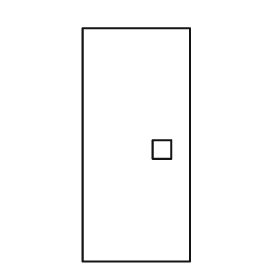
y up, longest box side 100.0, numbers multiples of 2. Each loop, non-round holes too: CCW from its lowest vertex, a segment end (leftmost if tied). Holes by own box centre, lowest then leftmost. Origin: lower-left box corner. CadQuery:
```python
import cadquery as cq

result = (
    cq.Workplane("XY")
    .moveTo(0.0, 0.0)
    .lineTo(46.0, 0.0)
    .lineTo(46.0, 100.0)
    .lineTo(0.0, 100.0)
    .close()
    .moveTo(30.0, 44.0)
    .lineTo(38.0, 44.0)
    .lineTo(38.0, 52.0)
    .lineTo(30.0, 52.0)
    .close()
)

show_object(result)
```